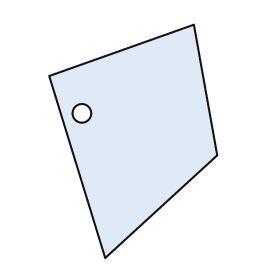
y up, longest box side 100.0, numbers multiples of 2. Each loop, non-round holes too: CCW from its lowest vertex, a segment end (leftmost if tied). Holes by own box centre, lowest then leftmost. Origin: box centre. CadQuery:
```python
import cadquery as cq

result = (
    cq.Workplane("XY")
    .moveTo(-12.0, -50.0)
    .lineTo(36.0, -6.0)
    .lineTo(26.0, 50.0)
    .lineTo(-36.0, 28.0)
    .close()
    .moveTo(-22.0, 12.0)
    .circle(4.0)
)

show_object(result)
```